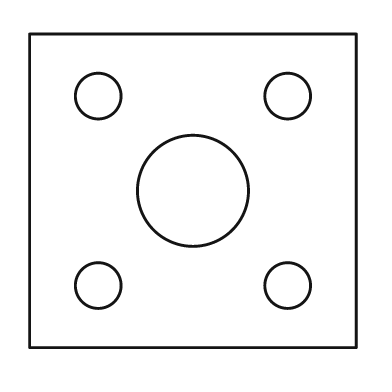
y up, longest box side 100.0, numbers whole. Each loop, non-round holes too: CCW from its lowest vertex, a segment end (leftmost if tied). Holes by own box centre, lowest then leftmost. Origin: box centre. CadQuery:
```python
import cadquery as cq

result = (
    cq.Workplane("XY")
    .moveTo(-50.0, -48.0)
    .lineTo(50.0, -48.0)
    .lineTo(50.0, 48.0)
    .lineTo(-50.0, 48.0)
    .close()
    .moveTo(-29.0, -29.0)
    .circle(7.0)
    .moveTo(29.0, -29.0)
    .circle(7.0)
    .moveTo(0.0, 0.0)
    .circle(17.0)
    .moveTo(-29.0, 29.0)
    .circle(7.0)
    .moveTo(29.0, 29.0)
    .circle(7.0)
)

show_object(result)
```